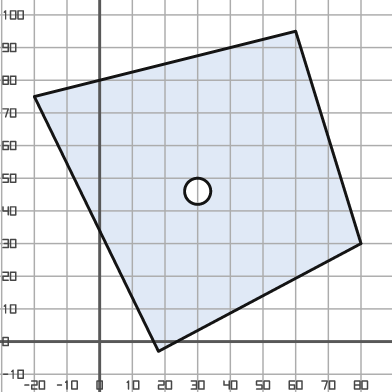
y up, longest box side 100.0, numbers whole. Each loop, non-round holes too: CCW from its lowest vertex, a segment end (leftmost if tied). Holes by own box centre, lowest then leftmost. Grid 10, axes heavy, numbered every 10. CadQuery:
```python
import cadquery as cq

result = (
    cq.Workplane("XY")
    .moveTo(18.0, -3.0)
    .lineTo(80.0, 30.0)
    .lineTo(60.0, 95.0)
    .lineTo(-20.0, 75.0)
    .close()
    .moveTo(30.0, 46.0)
    .circle(4.0)
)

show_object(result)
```